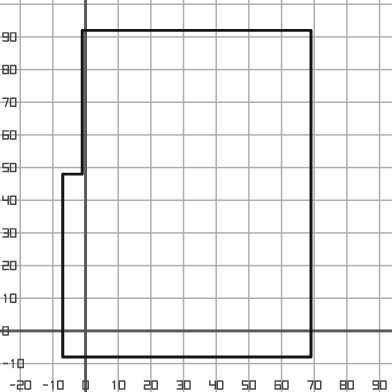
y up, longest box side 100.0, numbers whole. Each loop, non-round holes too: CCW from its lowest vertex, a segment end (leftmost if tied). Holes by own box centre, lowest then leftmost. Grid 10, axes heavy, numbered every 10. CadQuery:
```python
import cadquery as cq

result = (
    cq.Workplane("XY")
    .moveTo(-7.0, -8.0)
    .lineTo(69.0, -8.0)
    .lineTo(69.0, 92.0)
    .lineTo(-1.0, 92.0)
    .lineTo(-1.0, 48.0)
    .lineTo(-7.0, 48.0)
    .close()
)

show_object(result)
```